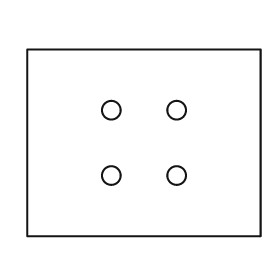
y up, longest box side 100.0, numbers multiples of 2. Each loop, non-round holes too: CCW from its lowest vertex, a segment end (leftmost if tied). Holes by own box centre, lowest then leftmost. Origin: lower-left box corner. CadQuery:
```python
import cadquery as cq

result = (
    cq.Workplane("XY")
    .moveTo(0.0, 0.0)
    .lineTo(100.0, 0.0)
    .lineTo(100.0, 80.0)
    .lineTo(0.0, 80.0)
    .close()
    .moveTo(36.0, 26.0)
    .circle(4.0)
    .moveTo(64.0, 26.0)
    .circle(4.0)
    .moveTo(36.0, 54.0)
    .circle(4.0)
    .moveTo(64.0, 54.0)
    .circle(4.0)
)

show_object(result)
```